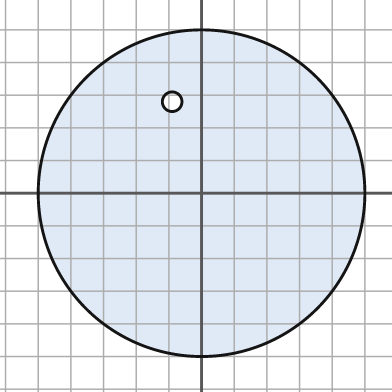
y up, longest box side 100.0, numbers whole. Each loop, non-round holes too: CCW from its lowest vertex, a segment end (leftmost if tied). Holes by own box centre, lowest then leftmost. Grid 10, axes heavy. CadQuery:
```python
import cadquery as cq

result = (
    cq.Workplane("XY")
    .moveTo(0.0, 0.0)
    .circle(50.0)
    .moveTo(-9.0, 28.0)
    .circle(3.0)
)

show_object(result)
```